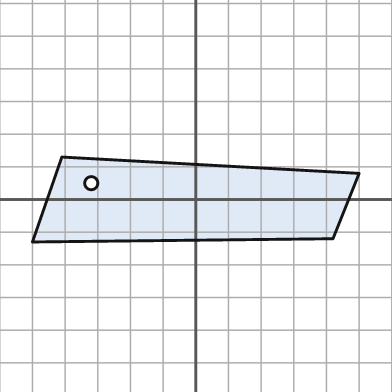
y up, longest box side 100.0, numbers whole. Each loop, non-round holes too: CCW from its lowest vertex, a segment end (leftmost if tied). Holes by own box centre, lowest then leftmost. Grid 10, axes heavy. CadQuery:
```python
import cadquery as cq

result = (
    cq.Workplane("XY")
    .moveTo(-50.0, -13.0)
    .lineTo(42.0, -12.0)
    .lineTo(50.0, 8.0)
    .lineTo(-41.0, 13.0)
    .close()
    .moveTo(-32.0, 5.0)
    .circle(2.0)
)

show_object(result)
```